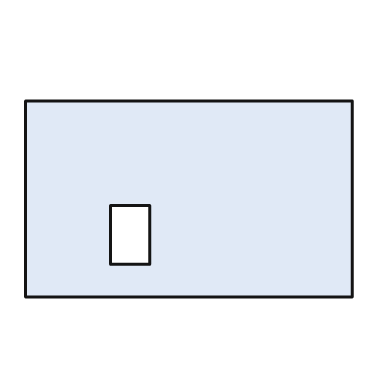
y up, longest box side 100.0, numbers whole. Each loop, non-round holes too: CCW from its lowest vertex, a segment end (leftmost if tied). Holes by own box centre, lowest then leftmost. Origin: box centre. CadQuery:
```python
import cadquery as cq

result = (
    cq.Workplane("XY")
    .moveTo(-50.0, -30.0)
    .lineTo(50.0, -30.0)
    .lineTo(50.0, 30.0)
    .lineTo(-50.0, 30.0)
    .close()
    .moveTo(-24.0, -20.0)
    .lineTo(-12.0, -20.0)
    .lineTo(-12.0, -2.0)
    .lineTo(-24.0, -2.0)
    .close()
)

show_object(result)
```